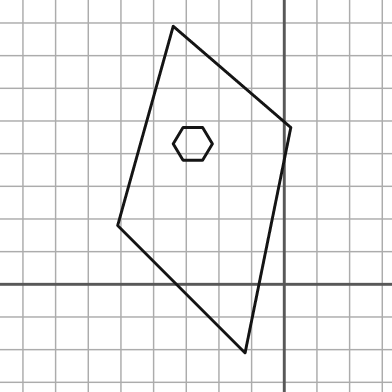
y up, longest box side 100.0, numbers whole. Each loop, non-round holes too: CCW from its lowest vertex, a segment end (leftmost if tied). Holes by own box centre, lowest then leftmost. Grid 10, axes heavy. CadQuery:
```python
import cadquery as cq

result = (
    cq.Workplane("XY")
    .moveTo(-12.0, -21.0)
    .lineTo(2.0, 48.0)
    .lineTo(-34.0, 79.0)
    .lineTo(-51.0, 18.0)
    .close()
    .moveTo(-31.0, 38.0)
    .lineTo(-25.0, 38.0)
    .lineTo(-22.0, 43.0)
    .lineTo(-25.0, 48.0)
    .lineTo(-31.0, 48.0)
    .lineTo(-34.0, 43.0)
    .close()
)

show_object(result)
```